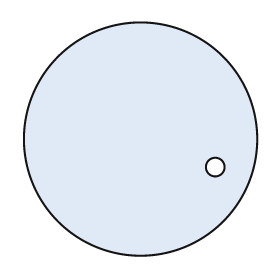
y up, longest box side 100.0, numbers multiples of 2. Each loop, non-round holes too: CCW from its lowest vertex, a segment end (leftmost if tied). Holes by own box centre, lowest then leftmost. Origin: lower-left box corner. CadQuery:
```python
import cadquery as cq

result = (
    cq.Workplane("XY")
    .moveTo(50.0, 50.0)
    .circle(50.0)
    .moveTo(82.0, 38.0)
    .circle(4.0)
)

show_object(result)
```